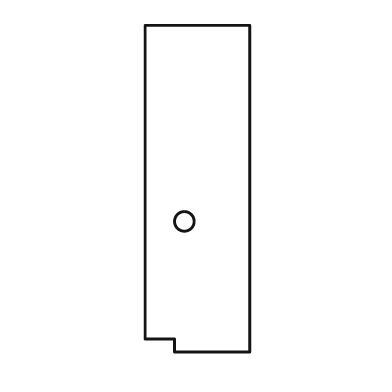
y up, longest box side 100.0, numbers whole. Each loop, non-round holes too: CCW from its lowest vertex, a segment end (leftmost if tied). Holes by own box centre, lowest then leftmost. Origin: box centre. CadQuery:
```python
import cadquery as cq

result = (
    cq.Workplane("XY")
    .moveTo(-7.0, -50.0)
    .lineTo(16.0, -50.0)
    .lineTo(16.0, 50.0)
    .lineTo(-16.0, 50.0)
    .lineTo(-16.0, -46.0)
    .lineTo(-7.0, -46.0)
    .close()
    .moveTo(-4.0, -10.0)
    .circle(3.0)
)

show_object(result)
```